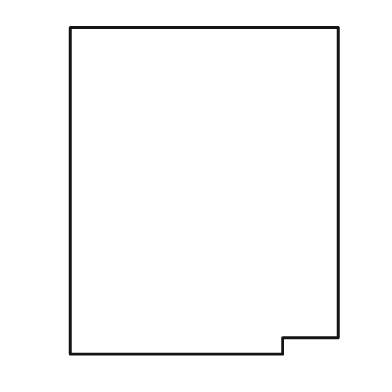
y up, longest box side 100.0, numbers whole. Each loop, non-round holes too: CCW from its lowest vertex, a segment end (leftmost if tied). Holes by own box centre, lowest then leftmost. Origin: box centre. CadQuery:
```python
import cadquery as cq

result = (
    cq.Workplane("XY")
    .moveTo(-41.0, -50.0)
    .lineTo(24.0, -50.0)
    .lineTo(24.0, -45.0)
    .lineTo(41.0, -45.0)
    .lineTo(41.0, 50.0)
    .lineTo(-41.0, 50.0)
    .close()
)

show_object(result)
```